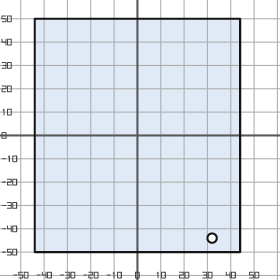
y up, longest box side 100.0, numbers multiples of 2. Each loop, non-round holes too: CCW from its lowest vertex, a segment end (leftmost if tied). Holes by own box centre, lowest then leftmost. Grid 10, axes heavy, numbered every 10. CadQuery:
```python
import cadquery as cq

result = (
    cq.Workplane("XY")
    .moveTo(-44.0, -50.0)
    .lineTo(44.0, -50.0)
    .lineTo(44.0, 50.0)
    .lineTo(-44.0, 50.0)
    .close()
    .moveTo(32.0, -44.0)
    .circle(2.0)
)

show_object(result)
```